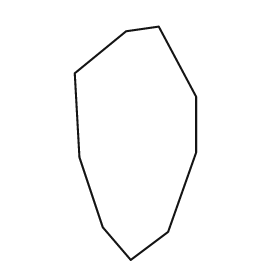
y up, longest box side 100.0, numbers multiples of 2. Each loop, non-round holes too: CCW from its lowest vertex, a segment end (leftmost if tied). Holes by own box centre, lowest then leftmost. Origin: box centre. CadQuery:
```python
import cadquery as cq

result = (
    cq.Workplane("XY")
    .moveTo(-2.0, -50.0)
    .lineTo(14.0, -38.0)
    .lineTo(26.0, -4.0)
    .lineTo(26.0, 20.0)
    .lineTo(10.0, 50.0)
    .lineTo(-4.0, 48.0)
    .lineTo(-26.0, 30.0)
    .lineTo(-24.0, -6.0)
    .lineTo(-14.0, -36.0)
    .close()
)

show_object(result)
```